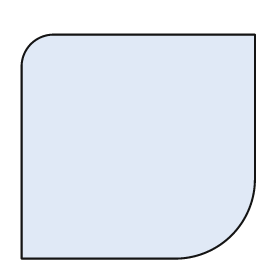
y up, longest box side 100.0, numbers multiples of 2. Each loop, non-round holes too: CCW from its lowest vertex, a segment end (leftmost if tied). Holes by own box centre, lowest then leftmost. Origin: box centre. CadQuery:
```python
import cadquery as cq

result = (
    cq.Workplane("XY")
    .moveTo(-50.0, -48.0)
    .lineTo(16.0, -48.0)
    .threePointArc((40.0, -38.0), (50.0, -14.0))
    .lineTo(50.0, 48.0)
    .lineTo(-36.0, 48.0)
    .threePointArc((-46.0, 44.0), (-50.0, 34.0))
    .close()
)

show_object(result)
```